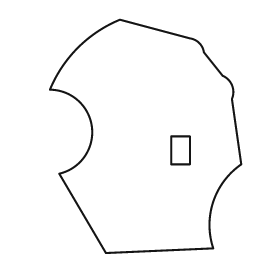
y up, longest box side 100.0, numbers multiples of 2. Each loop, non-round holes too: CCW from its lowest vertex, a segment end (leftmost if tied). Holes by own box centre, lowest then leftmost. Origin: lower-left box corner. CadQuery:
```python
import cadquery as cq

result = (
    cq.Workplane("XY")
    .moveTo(24.0, 0.0)
    .lineTo(70.0, 2.0)
    .threePointArc((70.0, 22.0), (82.0, 38.0))
    .lineTo(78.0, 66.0)
    .threePointArc((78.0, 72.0), (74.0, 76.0))
    .lineTo(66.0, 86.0)
    .threePointArc((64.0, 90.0), (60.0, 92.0))
    .lineTo(30.0, 100.0)
    .threePointArc((12.0, 88.0), (0.0, 70.0))
    .threePointArc((18.0, 54.0), (4.0, 34.0))
    .close()
    .moveTo(52.0, 38.0)
    .lineTo(60.0, 38.0)
    .lineTo(60.0, 50.0)
    .lineTo(52.0, 50.0)
    .close()
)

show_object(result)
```